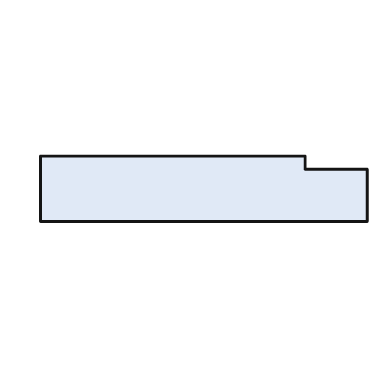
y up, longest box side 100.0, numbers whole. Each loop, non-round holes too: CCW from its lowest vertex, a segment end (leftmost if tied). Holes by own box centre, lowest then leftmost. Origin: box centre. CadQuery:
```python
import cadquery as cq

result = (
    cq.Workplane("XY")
    .moveTo(-50.0, -10.0)
    .lineTo(50.0, -10.0)
    .lineTo(50.0, 6.0)
    .lineTo(31.0, 6.0)
    .lineTo(31.0, 10.0)
    .lineTo(-50.0, 10.0)
    .close()
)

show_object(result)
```